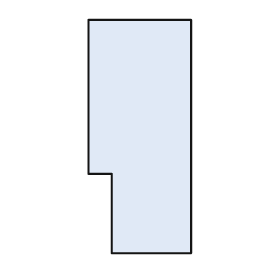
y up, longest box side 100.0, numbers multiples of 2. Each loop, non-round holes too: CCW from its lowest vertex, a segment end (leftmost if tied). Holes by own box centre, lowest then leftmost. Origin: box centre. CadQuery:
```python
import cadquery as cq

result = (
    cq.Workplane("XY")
    .moveTo(-12.0, -50.0)
    .lineTo(22.0, -50.0)
    .lineTo(22.0, 50.0)
    .lineTo(-22.0, 50.0)
    .lineTo(-22.0, -16.0)
    .lineTo(-12.0, -16.0)
    .close()
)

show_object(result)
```